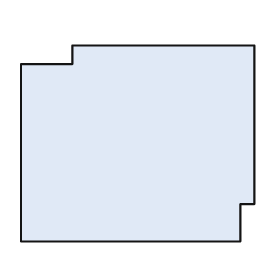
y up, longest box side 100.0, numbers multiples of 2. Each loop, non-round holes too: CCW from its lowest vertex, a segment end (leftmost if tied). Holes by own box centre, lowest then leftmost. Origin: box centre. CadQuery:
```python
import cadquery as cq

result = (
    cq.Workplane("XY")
    .moveTo(-50.0, -42.0)
    .lineTo(44.0, -42.0)
    .lineTo(44.0, -26.0)
    .lineTo(50.0, -26.0)
    .lineTo(50.0, 42.0)
    .lineTo(-28.0, 42.0)
    .lineTo(-28.0, 34.0)
    .lineTo(-50.0, 34.0)
    .close()
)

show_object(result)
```